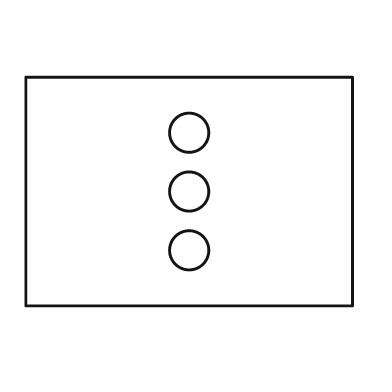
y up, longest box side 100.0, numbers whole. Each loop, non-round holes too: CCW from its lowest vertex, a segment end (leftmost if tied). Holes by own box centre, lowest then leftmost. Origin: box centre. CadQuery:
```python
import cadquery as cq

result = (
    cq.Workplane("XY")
    .moveTo(-50.0, -35.0)
    .lineTo(50.0, -35.0)
    .lineTo(50.0, 35.0)
    .lineTo(-50.0, 35.0)
    .close()
    .moveTo(0.0, -18.0)
    .circle(6.0)
    .moveTo(0.0, 0.0)
    .circle(6.0)
    .moveTo(0.0, 18.0)
    .circle(6.0)
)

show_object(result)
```